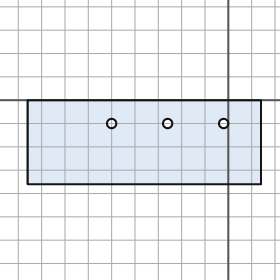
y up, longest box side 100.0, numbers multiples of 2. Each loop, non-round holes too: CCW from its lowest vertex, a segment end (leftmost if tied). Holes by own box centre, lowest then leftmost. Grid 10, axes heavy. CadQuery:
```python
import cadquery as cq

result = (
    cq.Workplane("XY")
    .moveTo(-86.0, -36.0)
    .lineTo(14.0, -36.0)
    .lineTo(14.0, 0.0)
    .lineTo(-86.0, 0.0)
    .close()
    .moveTo(-50.0, -10.0)
    .circle(2.0)
    .moveTo(-26.0, -10.0)
    .circle(2.0)
    .moveTo(-2.0, -10.0)
    .circle(2.0)
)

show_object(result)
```